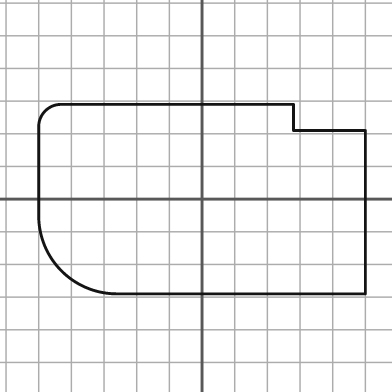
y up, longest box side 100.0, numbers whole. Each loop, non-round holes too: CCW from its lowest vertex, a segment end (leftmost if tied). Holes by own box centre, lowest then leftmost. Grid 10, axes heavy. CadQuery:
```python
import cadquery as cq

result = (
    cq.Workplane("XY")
    .moveTo(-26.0, -29.0)
    .lineTo(50.0, -29.0)
    .lineTo(50.0, 21.0)
    .lineTo(28.0, 21.0)
    .lineTo(28.0, 29.0)
    .lineTo(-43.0, 29.0)
    .threePointArc((-48.0, 27.0), (-50.0, 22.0))
    .lineTo(-50.0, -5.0)
    .threePointArc((-43.0, -22.0), (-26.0, -29.0))
    .close()
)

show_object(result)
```